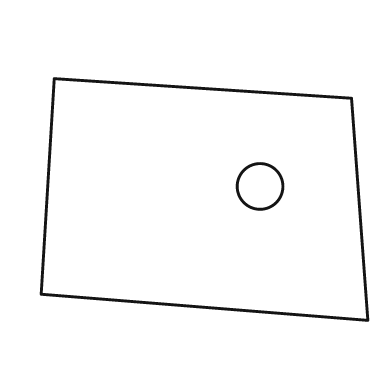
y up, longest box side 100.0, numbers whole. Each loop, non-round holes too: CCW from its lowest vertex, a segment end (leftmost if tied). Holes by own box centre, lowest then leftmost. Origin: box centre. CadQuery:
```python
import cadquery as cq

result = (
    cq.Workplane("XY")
    .moveTo(50.0, -37.0)
    .lineTo(45.0, 31.0)
    .lineTo(-46.0, 37.0)
    .lineTo(-50.0, -29.0)
    .close()
    .moveTo(17.0, 4.0)
    .circle(7.0)
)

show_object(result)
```